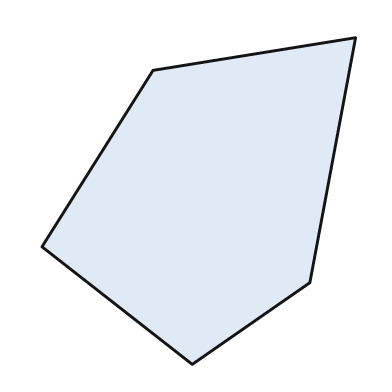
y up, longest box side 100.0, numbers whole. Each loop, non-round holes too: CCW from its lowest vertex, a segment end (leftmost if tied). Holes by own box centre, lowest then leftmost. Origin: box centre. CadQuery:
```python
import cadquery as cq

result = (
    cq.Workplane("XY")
    .moveTo(-2.0, -50.0)
    .lineTo(34.0, -25.0)
    .lineTo(48.0, 50.0)
    .lineTo(-14.0, 40.0)
    .lineTo(-48.0, -14.0)
    .close()
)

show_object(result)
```